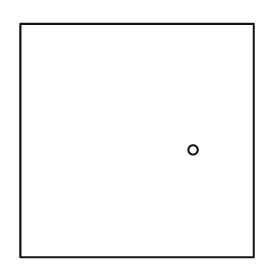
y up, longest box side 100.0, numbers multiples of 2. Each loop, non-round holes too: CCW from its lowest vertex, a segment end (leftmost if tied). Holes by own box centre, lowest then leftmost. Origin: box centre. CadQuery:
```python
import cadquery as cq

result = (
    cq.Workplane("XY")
    .moveTo(-50.0, -50.0)
    .lineTo(50.0, -50.0)
    .lineTo(50.0, 50.0)
    .lineTo(-50.0, 50.0)
    .close()
    .moveTo(24.0, -4.0)
    .circle(2.0)
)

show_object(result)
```